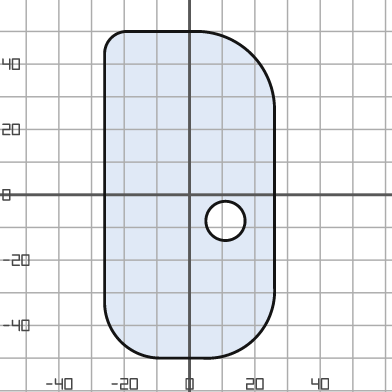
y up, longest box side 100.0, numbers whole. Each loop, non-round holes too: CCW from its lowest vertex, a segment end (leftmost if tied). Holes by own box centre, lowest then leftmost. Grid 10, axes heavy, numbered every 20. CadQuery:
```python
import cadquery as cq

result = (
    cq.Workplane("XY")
    .moveTo(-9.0, -50.0)
    .lineTo(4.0, -50.0)
    .threePointArc((20.0, -44.0), (26.0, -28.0))
    .lineTo(26.0, 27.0)
    .threePointArc((19.0, 43.0), (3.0, 50.0))
    .lineTo(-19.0, 50.0)
    .threePointArc((-24.0, 48.0), (-26.0, 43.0))
    .lineTo(-26.0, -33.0)
    .threePointArc((-21.0, -45.0), (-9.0, -50.0))
    .close()
    .moveTo(11.0, -8.0)
    .circle(6.0)
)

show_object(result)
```